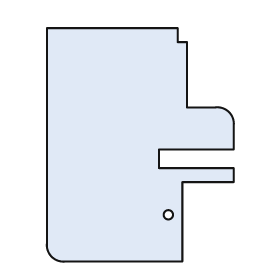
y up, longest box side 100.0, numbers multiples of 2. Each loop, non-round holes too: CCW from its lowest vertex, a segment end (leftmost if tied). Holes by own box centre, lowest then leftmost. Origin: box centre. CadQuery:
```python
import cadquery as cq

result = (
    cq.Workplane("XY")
    .moveTo(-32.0, -50.0)
    .lineTo(18.0, -50.0)
    .lineTo(18.0, -16.0)
    .lineTo(40.0, -16.0)
    .lineTo(40.0, -10.0)
    .lineTo(8.0, -10.0)
    .lineTo(8.0, -2.0)
    .lineTo(40.0, -2.0)
    .lineTo(40.0, 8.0)
    .threePointArc((38.0, 14.0), (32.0, 16.0))
    .lineTo(20.0, 16.0)
    .lineTo(20.0, 44.0)
    .lineTo(16.0, 44.0)
    .lineTo(16.0, 50.0)
    .lineTo(-40.0, 50.0)
    .lineTo(-40.0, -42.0)
    .threePointArc((-38.0, -48.0), (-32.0, -50.0))
    .close()
    .moveTo(12.0, -30.0)
    .circle(2.0)
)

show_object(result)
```